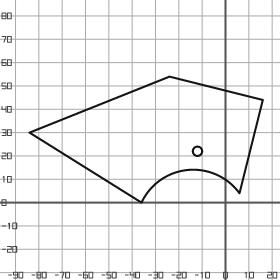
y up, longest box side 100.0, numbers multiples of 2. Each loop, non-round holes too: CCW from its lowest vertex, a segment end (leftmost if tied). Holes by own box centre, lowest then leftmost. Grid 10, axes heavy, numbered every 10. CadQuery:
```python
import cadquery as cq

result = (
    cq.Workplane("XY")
    .moveTo(-36.0, 0.0)
    .threePointArc((-16.0, 14.0), (6.0, 4.0))
    .lineTo(16.0, 44.0)
    .lineTo(-24.0, 54.0)
    .lineTo(-84.0, 30.0)
    .close()
    .moveTo(-12.0, 22.0)
    .circle(2.0)
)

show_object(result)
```